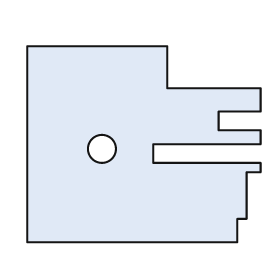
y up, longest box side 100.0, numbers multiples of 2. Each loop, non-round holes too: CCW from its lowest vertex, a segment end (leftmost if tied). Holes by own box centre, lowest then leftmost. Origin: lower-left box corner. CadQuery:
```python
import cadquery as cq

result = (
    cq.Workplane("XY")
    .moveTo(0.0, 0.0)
    .lineTo(90.0, 0.0)
    .lineTo(90.0, 10.0)
    .lineTo(94.0, 10.0)
    .lineTo(94.0, 30.0)
    .lineTo(100.0, 30.0)
    .lineTo(100.0, 34.0)
    .lineTo(54.0, 34.0)
    .lineTo(54.0, 42.0)
    .lineTo(100.0, 42.0)
    .lineTo(100.0, 48.0)
    .lineTo(82.0, 48.0)
    .lineTo(82.0, 56.0)
    .lineTo(100.0, 56.0)
    .lineTo(100.0, 66.0)
    .lineTo(60.0, 66.0)
    .lineTo(60.0, 84.0)
    .lineTo(0.0, 84.0)
    .close()
    .moveTo(32.0, 40.0)
    .circle(6.0)
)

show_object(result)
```